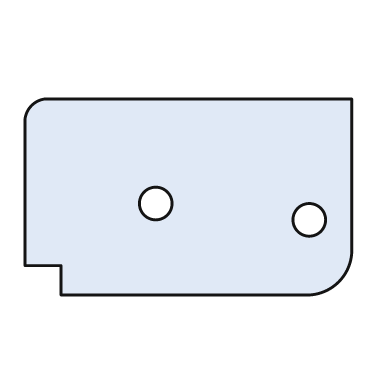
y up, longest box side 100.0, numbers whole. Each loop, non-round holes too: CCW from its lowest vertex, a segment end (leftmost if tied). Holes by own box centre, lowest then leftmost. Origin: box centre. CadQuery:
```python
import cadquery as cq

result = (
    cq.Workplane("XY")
    .moveTo(-39.0, -30.0)
    .lineTo(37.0, -30.0)
    .threePointArc((46.0, -26.0), (50.0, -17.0))
    .lineTo(50.0, 30.0)
    .lineTo(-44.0, 30.0)
    .threePointArc((-48.0, 28.0), (-50.0, 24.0))
    .lineTo(-50.0, -21.0)
    .lineTo(-39.0, -21.0)
    .close()
    .moveTo(37.0, -7.0)
    .circle(5.0)
    .moveTo(-10.0, -2.0)
    .circle(5.0)
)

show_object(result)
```